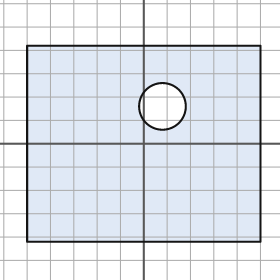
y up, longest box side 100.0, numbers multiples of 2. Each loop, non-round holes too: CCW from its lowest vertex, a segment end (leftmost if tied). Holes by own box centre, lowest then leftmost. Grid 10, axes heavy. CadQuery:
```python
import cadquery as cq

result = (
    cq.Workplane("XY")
    .moveTo(-50.0, -42.0)
    .lineTo(50.0, -42.0)
    .lineTo(50.0, 42.0)
    .lineTo(-50.0, 42.0)
    .close()
    .moveTo(8.0, 16.0)
    .circle(10.0)
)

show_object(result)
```